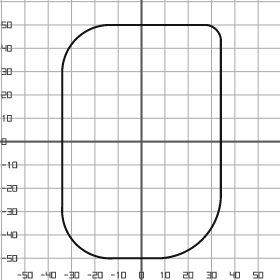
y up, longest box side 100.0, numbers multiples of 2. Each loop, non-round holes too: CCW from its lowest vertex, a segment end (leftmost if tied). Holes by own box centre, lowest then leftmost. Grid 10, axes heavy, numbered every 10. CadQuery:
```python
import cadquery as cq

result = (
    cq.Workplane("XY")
    .moveTo(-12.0, -50.0)
    .lineTo(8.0, -50.0)
    .threePointArc((26.0, -42.0), (34.0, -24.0))
    .lineTo(34.0, 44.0)
    .threePointArc((32.0, 48.0), (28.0, 50.0))
    .lineTo(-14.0, 50.0)
    .threePointArc((-28.0, 44.0), (-34.0, 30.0))
    .lineTo(-34.0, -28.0)
    .threePointArc((-28.0, -44.0), (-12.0, -50.0))
    .close()
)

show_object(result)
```